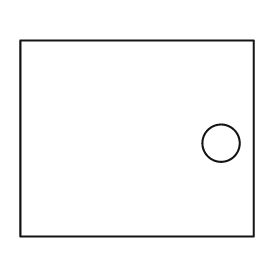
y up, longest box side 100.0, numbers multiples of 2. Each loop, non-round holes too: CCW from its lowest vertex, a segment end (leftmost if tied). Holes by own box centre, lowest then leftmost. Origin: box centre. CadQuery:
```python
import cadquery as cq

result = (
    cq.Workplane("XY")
    .moveTo(-50.0, -42.0)
    .lineTo(50.0, -42.0)
    .lineTo(50.0, 42.0)
    .lineTo(-50.0, 42.0)
    .close()
    .moveTo(36.0, -2.0)
    .circle(8.0)
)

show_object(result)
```